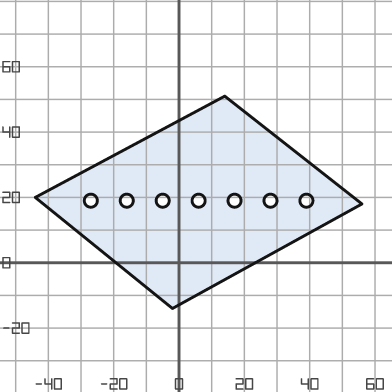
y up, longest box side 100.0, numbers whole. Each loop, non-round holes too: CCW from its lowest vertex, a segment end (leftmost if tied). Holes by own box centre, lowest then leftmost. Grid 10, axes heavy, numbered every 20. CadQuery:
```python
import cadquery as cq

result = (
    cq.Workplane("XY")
    .moveTo(-2.0, -14.0)
    .lineTo(56.0, 18.0)
    .lineTo(14.0, 51.0)
    .lineTo(-44.0, 20.0)
    .close()
    .moveTo(-27.0, 19.0)
    .circle(2.0)
    .moveTo(-16.0, 19.0)
    .circle(2.0)
    .moveTo(-5.0, 19.0)
    .circle(2.0)
    .moveTo(6.0, 19.0)
    .circle(2.0)
    .moveTo(17.0, 19.0)
    .circle(2.0)
    .moveTo(28.0, 19.0)
    .circle(2.0)
    .moveTo(39.0, 19.0)
    .circle(2.0)
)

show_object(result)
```